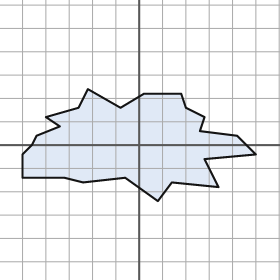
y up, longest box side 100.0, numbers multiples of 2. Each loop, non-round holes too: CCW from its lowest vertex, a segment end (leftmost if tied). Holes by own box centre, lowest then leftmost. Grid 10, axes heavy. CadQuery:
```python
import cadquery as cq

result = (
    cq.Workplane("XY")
    .moveTo(8.0, -24.0)
    .lineTo(14.0, -16.0)
    .lineTo(34.0, -18.0)
    .lineTo(28.0, -6.0)
    .lineTo(50.0, -4.0)
    .lineTo(42.0, 4.0)
    .lineTo(26.0, 6.0)
    .lineTo(28.0, 12.0)
    .lineTo(20.0, 16.0)
    .lineTo(18.0, 22.0)
    .lineTo(2.0, 22.0)
    .lineTo(-8.0, 16.0)
    .lineTo(-22.0, 24.0)
    .lineTo(-26.0, 16.0)
    .lineTo(-40.0, 12.0)
    .lineTo(-34.0, 8.0)
    .lineTo(-44.0, 4.0)
    .lineTo(-46.0, 0.0)
    .lineTo(-50.0, -4.0)
    .lineTo(-50.0, -14.0)
    .lineTo(-32.0, -14.0)
    .lineTo(-24.0, -16.0)
    .lineTo(-6.0, -14.0)
    .close()
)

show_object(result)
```